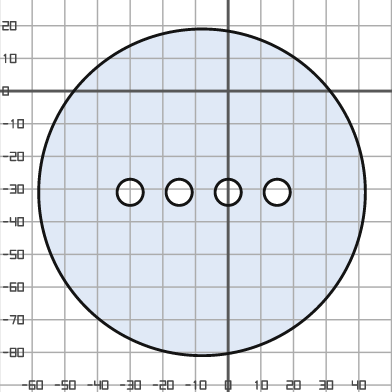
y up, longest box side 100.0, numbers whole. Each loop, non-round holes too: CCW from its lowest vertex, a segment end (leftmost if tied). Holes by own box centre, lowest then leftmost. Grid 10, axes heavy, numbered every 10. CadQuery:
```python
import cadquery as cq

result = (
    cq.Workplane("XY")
    .moveTo(-8.0, -31.0)
    .circle(50.0)
    .moveTo(-30.0, -31.0)
    .circle(4.0)
    .moveTo(-15.0, -31.0)
    .circle(4.0)
    .moveTo(0.0, -31.0)
    .circle(4.0)
    .moveTo(15.0, -31.0)
    .circle(4.0)
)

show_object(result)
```